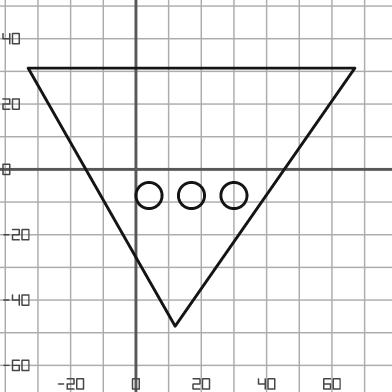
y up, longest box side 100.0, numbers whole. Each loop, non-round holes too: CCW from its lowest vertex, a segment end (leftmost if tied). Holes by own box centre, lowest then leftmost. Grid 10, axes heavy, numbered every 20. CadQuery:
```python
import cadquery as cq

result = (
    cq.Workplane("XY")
    .moveTo(12.0, -48.0)
    .lineTo(67.0, 31.0)
    .lineTo(-33.0, 31.0)
    .close()
    .moveTo(4.0, -8.0)
    .circle(4.0)
    .moveTo(17.0, -8.0)
    .circle(4.0)
    .moveTo(30.0, -8.0)
    .circle(4.0)
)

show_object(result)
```